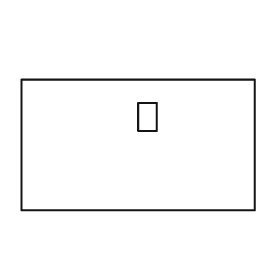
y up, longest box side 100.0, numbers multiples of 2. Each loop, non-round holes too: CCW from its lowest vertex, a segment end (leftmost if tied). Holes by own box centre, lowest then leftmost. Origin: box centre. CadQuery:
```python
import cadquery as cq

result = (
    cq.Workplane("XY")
    .moveTo(-50.0, -28.0)
    .lineTo(50.0, -28.0)
    .lineTo(50.0, 28.0)
    .lineTo(-50.0, 28.0)
    .close()
    .moveTo(0.0, 6.0)
    .lineTo(8.0, 6.0)
    .lineTo(8.0, 18.0)
    .lineTo(0.0, 18.0)
    .close()
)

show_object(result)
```